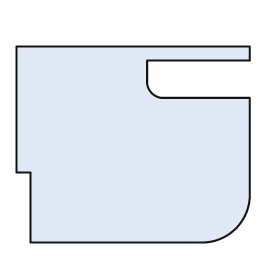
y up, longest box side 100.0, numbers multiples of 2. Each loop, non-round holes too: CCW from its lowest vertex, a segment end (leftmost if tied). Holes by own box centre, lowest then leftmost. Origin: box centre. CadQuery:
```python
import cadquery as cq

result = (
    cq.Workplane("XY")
    .moveTo(-44.0, -42.0)
    .lineTo(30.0, -42.0)
    .threePointArc((44.0, -36.0), (50.0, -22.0))
    .lineTo(50.0, 20.0)
    .lineTo(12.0, 20.0)
    .threePointArc((8.0, 22.0), (6.0, 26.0))
    .lineTo(6.0, 36.0)
    .lineTo(50.0, 36.0)
    .lineTo(50.0, 42.0)
    .lineTo(-50.0, 42.0)
    .lineTo(-50.0, -12.0)
    .lineTo(-44.0, -12.0)
    .close()
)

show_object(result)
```